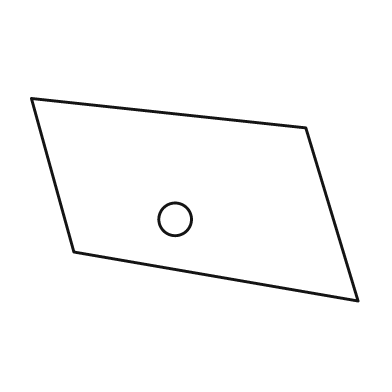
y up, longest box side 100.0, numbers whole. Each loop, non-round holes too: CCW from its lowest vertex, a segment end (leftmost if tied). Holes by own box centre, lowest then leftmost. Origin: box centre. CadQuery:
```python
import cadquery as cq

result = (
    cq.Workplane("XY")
    .moveTo(50.0, -31.0)
    .lineTo(34.0, 22.0)
    .lineTo(-50.0, 31.0)
    .lineTo(-37.0, -16.0)
    .close()
    .moveTo(-6.0, -6.0)
    .circle(5.0)
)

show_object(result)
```